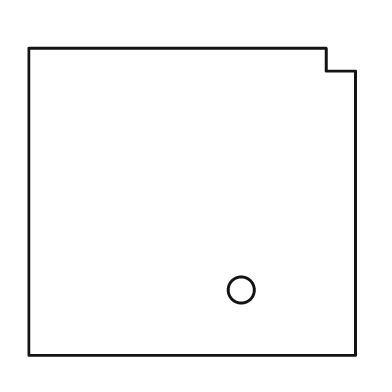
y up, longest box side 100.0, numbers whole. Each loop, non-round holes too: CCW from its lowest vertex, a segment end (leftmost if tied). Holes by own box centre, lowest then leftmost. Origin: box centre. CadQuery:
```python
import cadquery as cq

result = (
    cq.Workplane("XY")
    .moveTo(-50.0, -47.0)
    .lineTo(50.0, -47.0)
    .lineTo(50.0, 40.0)
    .lineTo(41.0, 40.0)
    .lineTo(41.0, 47.0)
    .lineTo(-50.0, 47.0)
    .close()
    .moveTo(15.0, -27.0)
    .circle(4.0)
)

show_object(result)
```